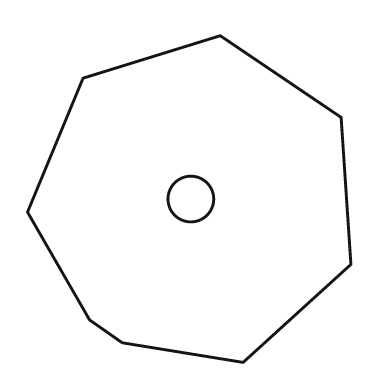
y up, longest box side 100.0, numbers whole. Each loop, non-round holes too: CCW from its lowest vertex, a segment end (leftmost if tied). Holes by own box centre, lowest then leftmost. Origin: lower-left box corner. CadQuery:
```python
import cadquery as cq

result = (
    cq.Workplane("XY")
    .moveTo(66.0, 0.0)
    .lineTo(99.0, 30.0)
    .lineTo(96.0, 75.0)
    .lineTo(59.0, 100.0)
    .lineTo(17.0, 87.0)
    .lineTo(0.0, 46.0)
    .lineTo(19.0, 13.0)
    .lineTo(29.0, 6.0)
    .close()
    .moveTo(50.0, 50.0)
    .circle(7.0)
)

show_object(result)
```